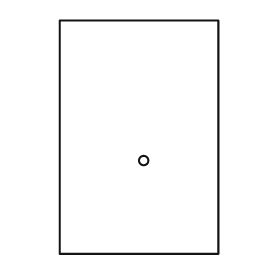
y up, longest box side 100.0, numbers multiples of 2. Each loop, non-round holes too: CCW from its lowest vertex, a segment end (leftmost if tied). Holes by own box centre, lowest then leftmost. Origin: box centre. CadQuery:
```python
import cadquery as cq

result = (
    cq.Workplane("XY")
    .moveTo(-34.0, -50.0)
    .lineTo(34.0, -50.0)
    .lineTo(34.0, 50.0)
    .lineTo(-34.0, 50.0)
    .close()
    .moveTo(2.0, -10.0)
    .circle(2.0)
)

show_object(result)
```